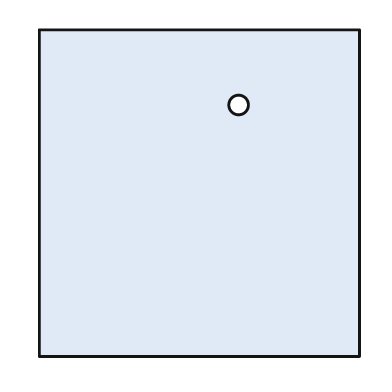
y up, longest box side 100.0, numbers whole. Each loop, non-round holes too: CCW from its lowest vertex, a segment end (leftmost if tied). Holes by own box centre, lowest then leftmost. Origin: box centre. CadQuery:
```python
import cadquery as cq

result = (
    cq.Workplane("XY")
    .moveTo(-49.0, -50.0)
    .lineTo(49.0, -50.0)
    .lineTo(49.0, 50.0)
    .lineTo(-49.0, 50.0)
    .close()
    .moveTo(12.0, 27.0)
    .circle(3.0)
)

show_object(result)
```